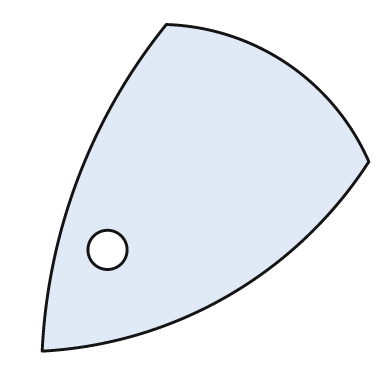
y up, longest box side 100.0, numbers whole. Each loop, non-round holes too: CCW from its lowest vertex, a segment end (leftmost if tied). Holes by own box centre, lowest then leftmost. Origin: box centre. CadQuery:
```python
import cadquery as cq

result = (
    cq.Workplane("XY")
    .moveTo(-50.0, -50.0)
    .threePointArc((7.0, -33.0), (50.0, 8.0))
    .threePointArc((25.0, 38.0), (-12.0, 50.0))
    .threePointArc((-39.0, 3.0), (-50.0, -50.0))
    .close()
    .moveTo(-30.0, -19.0)
    .circle(6.0)
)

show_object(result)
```